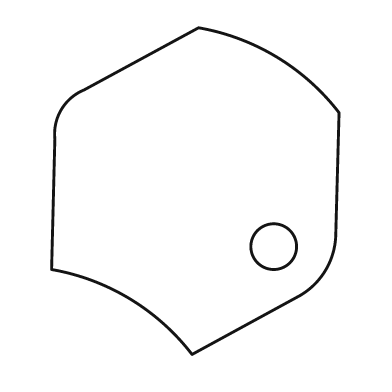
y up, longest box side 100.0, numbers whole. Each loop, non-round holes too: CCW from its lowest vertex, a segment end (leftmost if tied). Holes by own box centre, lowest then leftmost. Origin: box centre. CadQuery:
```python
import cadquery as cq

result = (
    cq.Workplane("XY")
    .moveTo(-1.0, -50.0)
    .lineTo(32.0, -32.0)
    .threePointArc((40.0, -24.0), (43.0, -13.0))
    .lineTo(44.0, 24.0)
    .threePointArc((25.0, 41.0), (1.0, 50.0))
    .lineTo(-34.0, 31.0)
    .threePointArc((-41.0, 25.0), (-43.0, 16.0))
    .lineTo(-44.0, -24.0)
    .threePointArc((-20.0, -33.0), (-1.0, -50.0))
    .close()
    .moveTo(24.0, -17.0)
    .circle(7.0)
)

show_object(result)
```